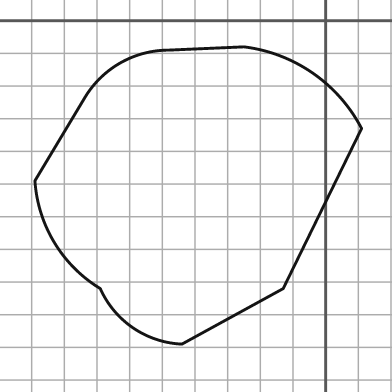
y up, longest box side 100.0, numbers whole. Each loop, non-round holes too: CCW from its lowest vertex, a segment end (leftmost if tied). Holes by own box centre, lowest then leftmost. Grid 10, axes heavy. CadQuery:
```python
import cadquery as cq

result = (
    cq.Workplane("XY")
    .moveTo(-44.0, -99.0)
    .lineTo(-13.0, -82.0)
    .lineTo(11.0, -33.0)
    .threePointArc((-4.0, -16.0), (-25.0, -8.0))
    .lineTo(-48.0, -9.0)
    .threePointArc((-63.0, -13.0), (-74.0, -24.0))
    .lineTo(-89.0, -49.0)
    .threePointArc((-83.0, -68.0), (-69.0, -82.0))
    .threePointArc((-59.0, -94.0), (-44.0, -99.0))
    .close()
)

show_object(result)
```